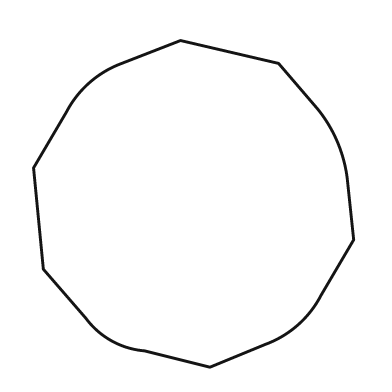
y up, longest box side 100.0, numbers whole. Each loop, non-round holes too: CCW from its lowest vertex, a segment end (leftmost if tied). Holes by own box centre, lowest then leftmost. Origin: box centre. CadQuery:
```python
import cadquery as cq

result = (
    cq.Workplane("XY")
    .moveTo(5.0, -50.0)
    .lineTo(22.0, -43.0)
    .threePointArc((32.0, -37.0), (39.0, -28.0))
    .lineTo(49.0, -11.0)
    .lineTo(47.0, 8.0)
    .threePointArc((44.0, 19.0), (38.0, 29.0))
    .lineTo(26.0, 43.0)
    .lineTo(-4.0, 50.0)
    .lineTo(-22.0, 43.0)
    .threePointArc((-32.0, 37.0), (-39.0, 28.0))
    .lineTo(-49.0, 11.0)
    .lineTo(-46.0, -20.0)
    .lineTo(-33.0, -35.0)
    .threePointArc((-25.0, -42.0), (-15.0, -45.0))
    .close()
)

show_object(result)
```